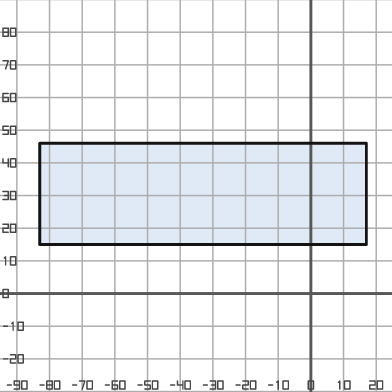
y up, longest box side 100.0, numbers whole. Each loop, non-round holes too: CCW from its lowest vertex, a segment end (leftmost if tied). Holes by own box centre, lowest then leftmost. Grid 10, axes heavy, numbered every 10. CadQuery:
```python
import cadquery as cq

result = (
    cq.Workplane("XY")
    .moveTo(-83.0, 15.0)
    .lineTo(17.0, 15.0)
    .lineTo(17.0, 46.0)
    .lineTo(-83.0, 46.0)
    .close()
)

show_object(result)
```